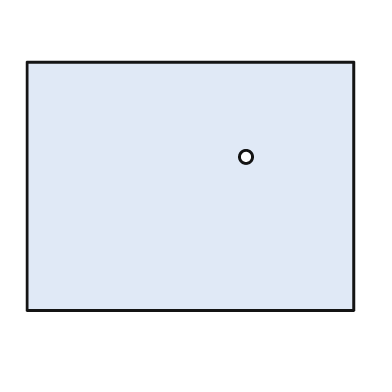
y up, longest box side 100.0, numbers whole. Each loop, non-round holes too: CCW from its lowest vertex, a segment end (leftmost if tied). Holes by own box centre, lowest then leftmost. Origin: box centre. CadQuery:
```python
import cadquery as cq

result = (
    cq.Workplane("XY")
    .moveTo(-50.0, -38.0)
    .lineTo(50.0, -38.0)
    .lineTo(50.0, 38.0)
    .lineTo(-50.0, 38.0)
    .close()
    .moveTo(17.0, 9.0)
    .circle(2.0)
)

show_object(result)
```